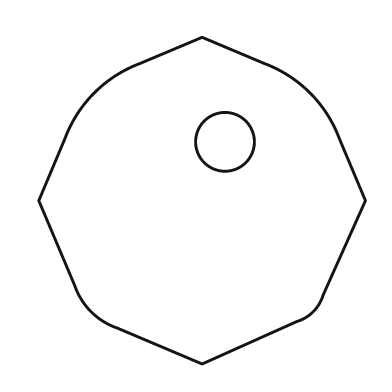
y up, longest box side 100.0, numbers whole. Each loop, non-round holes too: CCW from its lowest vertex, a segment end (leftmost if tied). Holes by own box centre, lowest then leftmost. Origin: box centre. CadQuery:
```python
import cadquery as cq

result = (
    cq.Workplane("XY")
    .moveTo(0.0, -50.0)
    .lineTo(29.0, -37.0)
    .threePointArc((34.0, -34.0), (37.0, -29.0))
    .lineTo(50.0, 0.0)
    .lineTo(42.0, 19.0)
    .threePointArc((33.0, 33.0), (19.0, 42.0))
    .lineTo(0.0, 50.0)
    .lineTo(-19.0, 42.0)
    .threePointArc((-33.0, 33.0), (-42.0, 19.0))
    .lineTo(-50.0, 0.0)
    .lineTo(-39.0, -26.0)
    .threePointArc((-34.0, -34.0), (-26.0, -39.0))
    .close()
    .moveTo(7.0, 18.0)
    .circle(9.0)
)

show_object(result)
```